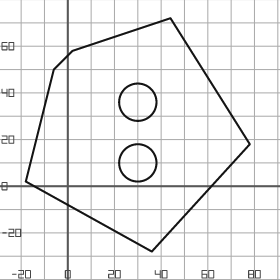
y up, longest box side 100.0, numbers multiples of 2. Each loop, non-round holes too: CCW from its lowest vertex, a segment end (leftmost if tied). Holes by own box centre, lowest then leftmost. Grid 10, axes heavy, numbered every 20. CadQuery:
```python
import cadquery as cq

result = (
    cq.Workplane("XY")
    .moveTo(36.0, -28.0)
    .lineTo(78.0, 18.0)
    .lineTo(44.0, 72.0)
    .lineTo(2.0, 58.0)
    .lineTo(-6.0, 50.0)
    .lineTo(-18.0, 2.0)
    .close()
    .moveTo(30.0, 10.0)
    .circle(8.0)
    .moveTo(30.0, 36.0)
    .circle(8.0)
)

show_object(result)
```